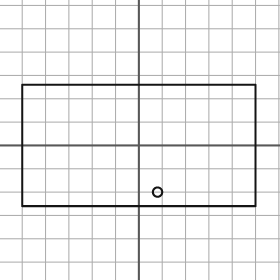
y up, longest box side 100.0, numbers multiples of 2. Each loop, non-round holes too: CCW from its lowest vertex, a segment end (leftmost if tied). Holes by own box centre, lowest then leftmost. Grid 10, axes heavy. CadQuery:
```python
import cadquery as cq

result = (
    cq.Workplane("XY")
    .moveTo(-50.0, -26.0)
    .lineTo(50.0, -26.0)
    .lineTo(50.0, 26.0)
    .lineTo(-50.0, 26.0)
    .close()
    .moveTo(8.0, -20.0)
    .circle(2.0)
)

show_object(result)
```